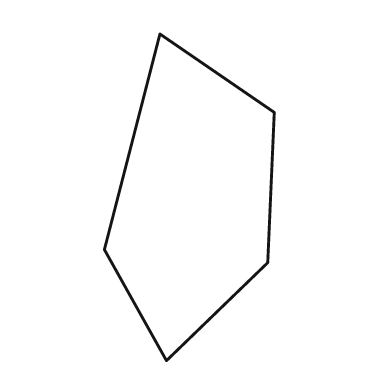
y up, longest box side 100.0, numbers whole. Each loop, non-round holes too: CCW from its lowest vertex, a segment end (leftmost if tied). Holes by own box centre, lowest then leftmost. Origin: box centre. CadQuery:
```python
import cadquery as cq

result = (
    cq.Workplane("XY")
    .moveTo(-7.0, -50.0)
    .lineTo(24.0, -20.0)
    .lineTo(26.0, 26.0)
    .lineTo(-9.0, 50.0)
    .lineTo(-26.0, -16.0)
    .close()
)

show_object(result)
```